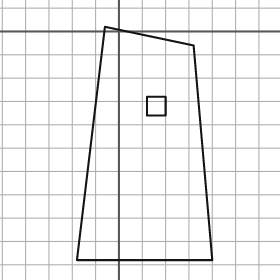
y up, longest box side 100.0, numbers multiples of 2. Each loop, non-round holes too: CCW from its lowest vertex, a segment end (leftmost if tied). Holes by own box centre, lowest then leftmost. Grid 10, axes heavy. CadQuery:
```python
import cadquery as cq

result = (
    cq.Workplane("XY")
    .moveTo(-18.0, -98.0)
    .lineTo(40.0, -98.0)
    .lineTo(32.0, -6.0)
    .lineTo(-6.0, 2.0)
    .close()
    .moveTo(12.0, -36.0)
    .lineTo(20.0, -36.0)
    .lineTo(20.0, -28.0)
    .lineTo(12.0, -28.0)
    .close()
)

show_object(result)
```